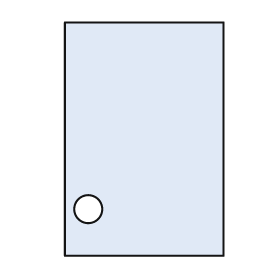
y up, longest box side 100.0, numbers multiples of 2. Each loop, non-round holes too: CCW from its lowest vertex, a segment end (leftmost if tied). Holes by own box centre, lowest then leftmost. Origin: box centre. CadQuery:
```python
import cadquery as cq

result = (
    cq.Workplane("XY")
    .moveTo(-34.0, -50.0)
    .lineTo(34.0, -50.0)
    .lineTo(34.0, 50.0)
    .lineTo(-34.0, 50.0)
    .close()
    .moveTo(-24.0, -30.0)
    .circle(6.0)
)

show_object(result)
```